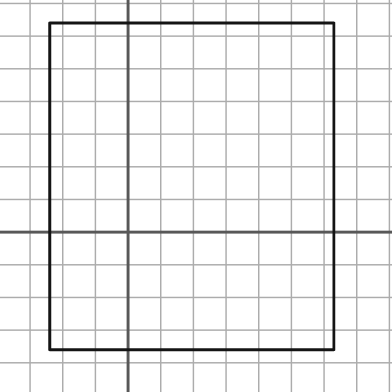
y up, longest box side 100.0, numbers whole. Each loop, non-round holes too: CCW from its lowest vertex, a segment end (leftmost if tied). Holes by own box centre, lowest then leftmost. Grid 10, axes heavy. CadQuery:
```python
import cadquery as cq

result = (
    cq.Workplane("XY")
    .moveTo(-24.0, -36.0)
    .lineTo(63.0, -36.0)
    .lineTo(63.0, 64.0)
    .lineTo(-24.0, 64.0)
    .close()
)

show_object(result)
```